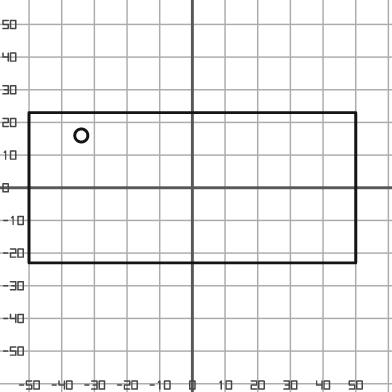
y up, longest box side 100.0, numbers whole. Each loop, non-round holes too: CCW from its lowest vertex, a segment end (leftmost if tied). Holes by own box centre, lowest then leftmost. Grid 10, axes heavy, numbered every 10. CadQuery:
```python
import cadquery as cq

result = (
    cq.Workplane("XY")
    .moveTo(-50.0, -23.0)
    .lineTo(50.0, -23.0)
    .lineTo(50.0, 23.0)
    .lineTo(-50.0, 23.0)
    .close()
    .moveTo(-34.0, 16.0)
    .circle(2.0)
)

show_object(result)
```